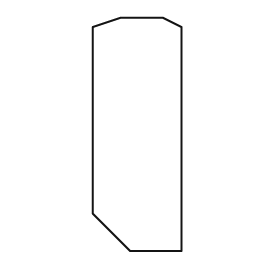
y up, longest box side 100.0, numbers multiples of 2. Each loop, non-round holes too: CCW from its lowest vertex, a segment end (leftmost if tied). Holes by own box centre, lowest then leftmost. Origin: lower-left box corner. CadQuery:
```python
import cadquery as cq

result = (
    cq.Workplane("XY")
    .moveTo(16.0, 0.0)
    .lineTo(38.0, 0.0)
    .lineTo(38.0, 96.0)
    .lineTo(30.0, 100.0)
    .lineTo(12.0, 100.0)
    .lineTo(0.0, 96.0)
    .lineTo(0.0, 16.0)
    .close()
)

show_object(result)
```